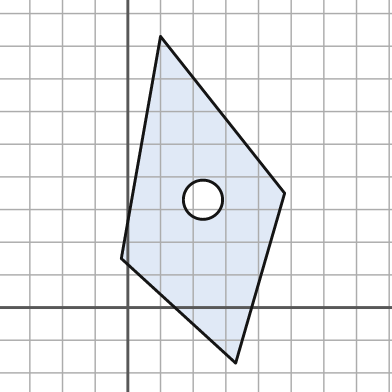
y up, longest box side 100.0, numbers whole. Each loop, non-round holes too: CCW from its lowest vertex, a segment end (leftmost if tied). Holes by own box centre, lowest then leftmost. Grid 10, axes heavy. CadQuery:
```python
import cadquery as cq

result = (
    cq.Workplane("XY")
    .moveTo(33.0, -17.0)
    .lineTo(48.0, 35.0)
    .lineTo(10.0, 83.0)
    .lineTo(-2.0, 15.0)
    .close()
    .moveTo(23.0, 33.0)
    .circle(6.0)
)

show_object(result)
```